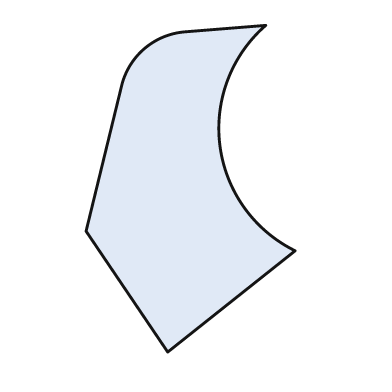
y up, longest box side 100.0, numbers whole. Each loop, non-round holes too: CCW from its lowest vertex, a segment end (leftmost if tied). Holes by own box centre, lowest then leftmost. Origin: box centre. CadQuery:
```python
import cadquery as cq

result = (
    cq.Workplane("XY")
    .moveTo(-7.0, -50.0)
    .lineTo(32.0, -19.0)
    .threePointArc((9.0, 13.0), (23.0, 50.0))
    .lineTo(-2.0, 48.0)
    .threePointArc((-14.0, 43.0), (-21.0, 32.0))
    .lineTo(-32.0, -13.0)
    .close()
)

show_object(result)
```